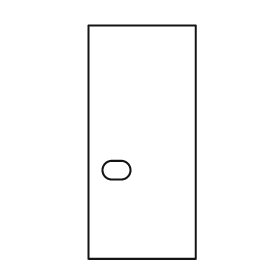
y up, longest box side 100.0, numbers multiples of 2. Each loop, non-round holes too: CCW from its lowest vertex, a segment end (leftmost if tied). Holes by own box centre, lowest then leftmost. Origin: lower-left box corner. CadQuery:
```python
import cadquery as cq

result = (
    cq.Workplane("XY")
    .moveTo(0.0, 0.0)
    .lineTo(46.0, 0.0)
    .lineTo(46.0, 100.0)
    .lineTo(0.0, 100.0)
    .close()
    .moveTo(10.0, 34.0)
    .lineTo(14.0, 34.0)
    .threePointArc((18.0, 38.0), (14.0, 42.0))
    .lineTo(10.0, 42.0)
    .threePointArc((6.0, 38.0), (10.0, 34.0))
    .close()
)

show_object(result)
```